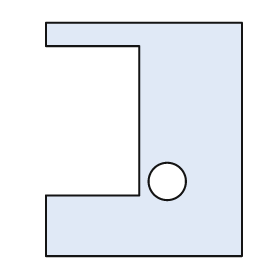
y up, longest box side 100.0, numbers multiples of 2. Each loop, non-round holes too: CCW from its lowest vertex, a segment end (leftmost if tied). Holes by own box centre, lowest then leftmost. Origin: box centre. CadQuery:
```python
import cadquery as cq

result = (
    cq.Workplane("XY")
    .moveTo(-42.0, -50.0)
    .lineTo(42.0, -50.0)
    .lineTo(42.0, 50.0)
    .lineTo(-42.0, 50.0)
    .lineTo(-42.0, 40.0)
    .lineTo(-2.0, 40.0)
    .lineTo(-2.0, -24.0)
    .lineTo(-42.0, -24.0)
    .close()
    .moveTo(10.0, -18.0)
    .circle(8.0)
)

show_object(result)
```